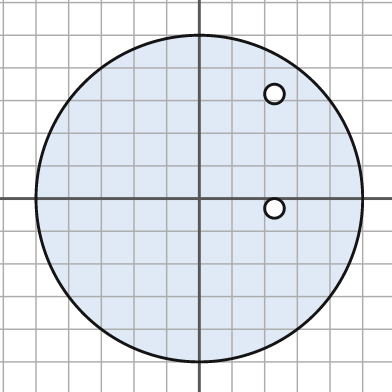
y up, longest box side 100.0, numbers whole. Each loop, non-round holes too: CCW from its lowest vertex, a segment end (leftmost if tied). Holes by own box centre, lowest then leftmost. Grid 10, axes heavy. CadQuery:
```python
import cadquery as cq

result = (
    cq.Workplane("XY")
    .moveTo(0.0, 0.0)
    .circle(50.0)
    .moveTo(23.0, -3.0)
    .circle(3.0)
    .moveTo(23.0, 32.0)
    .circle(3.0)
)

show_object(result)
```